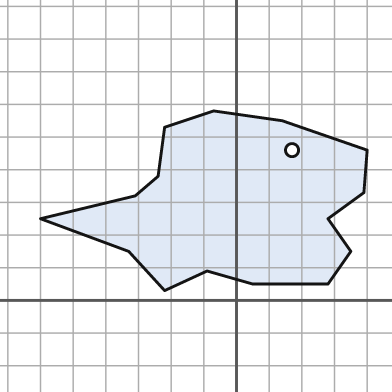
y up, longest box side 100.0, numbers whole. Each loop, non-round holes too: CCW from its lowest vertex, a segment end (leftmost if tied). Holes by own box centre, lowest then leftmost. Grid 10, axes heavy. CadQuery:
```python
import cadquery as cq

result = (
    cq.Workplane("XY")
    .moveTo(-22.0, 3.0)
    .lineTo(-9.0, 9.0)
    .lineTo(5.0, 5.0)
    .lineTo(28.0, 5.0)
    .lineTo(35.0, 15.0)
    .lineTo(28.0, 25.0)
    .lineTo(39.0, 33.0)
    .lineTo(40.0, 46.0)
    .lineTo(14.0, 55.0)
    .lineTo(-7.0, 58.0)
    .lineTo(-22.0, 53.0)
    .lineTo(-24.0, 38.0)
    .lineTo(-31.0, 32.0)
    .lineTo(-60.0, 25.0)
    .lineTo(-33.0, 15.0)
    .close()
    .moveTo(17.0, 46.0)
    .circle(2.0)
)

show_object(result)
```